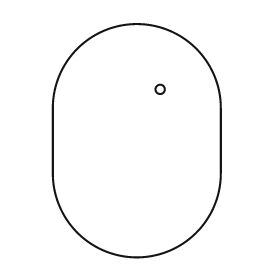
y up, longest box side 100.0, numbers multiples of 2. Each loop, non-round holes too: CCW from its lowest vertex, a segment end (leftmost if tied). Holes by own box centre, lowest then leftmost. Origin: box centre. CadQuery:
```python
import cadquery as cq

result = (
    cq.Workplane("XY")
    .moveTo(-36.0, -14.0)
    .threePointArc((0.0, -50.0), (36.0, -14.0))
    .lineTo(36.0, 14.0)
    .threePointArc((0.0, 50.0), (-36.0, 14.0))
    .close()
    .moveTo(10.0, 22.0)
    .circle(2.0)
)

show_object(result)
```